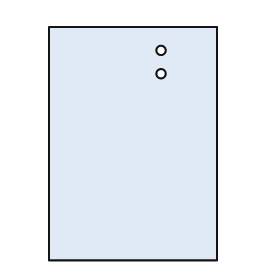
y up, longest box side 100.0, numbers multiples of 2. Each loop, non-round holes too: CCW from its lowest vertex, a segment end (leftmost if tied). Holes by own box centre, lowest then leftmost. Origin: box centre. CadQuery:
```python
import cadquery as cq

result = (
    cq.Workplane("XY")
    .moveTo(-36.0, -50.0)
    .lineTo(36.0, -50.0)
    .lineTo(36.0, 50.0)
    .lineTo(-36.0, 50.0)
    .close()
    .moveTo(12.0, 30.0)
    .circle(2.0)
    .moveTo(12.0, 40.0)
    .circle(2.0)
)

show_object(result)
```